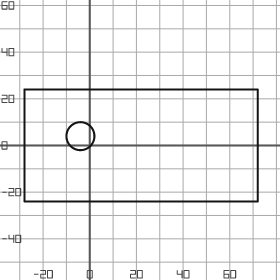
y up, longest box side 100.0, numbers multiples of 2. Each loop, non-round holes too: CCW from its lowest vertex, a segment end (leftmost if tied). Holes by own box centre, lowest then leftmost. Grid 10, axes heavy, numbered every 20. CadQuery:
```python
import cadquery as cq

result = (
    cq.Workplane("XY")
    .moveTo(-28.0, -24.0)
    .lineTo(72.0, -24.0)
    .lineTo(72.0, 24.0)
    .lineTo(-28.0, 24.0)
    .close()
    .moveTo(-4.0, 4.0)
    .circle(6.0)
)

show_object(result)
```